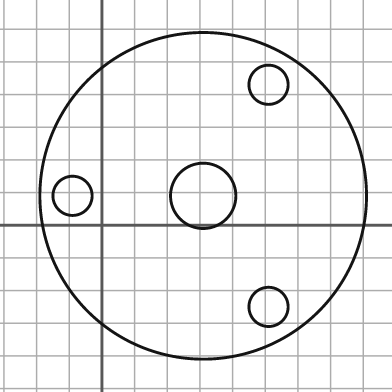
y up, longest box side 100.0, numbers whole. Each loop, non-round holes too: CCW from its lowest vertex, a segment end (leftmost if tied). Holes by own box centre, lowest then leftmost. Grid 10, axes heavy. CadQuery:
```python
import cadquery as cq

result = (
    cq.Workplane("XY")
    .moveTo(31.0, 9.0)
    .circle(50.0)
    .moveTo(51.0, -25.0)
    .circle(6.0)
    .moveTo(-9.0, 9.0)
    .circle(6.0)
    .moveTo(31.0, 9.0)
    .circle(10.0)
    .moveTo(51.0, 43.0)
    .circle(6.0)
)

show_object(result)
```